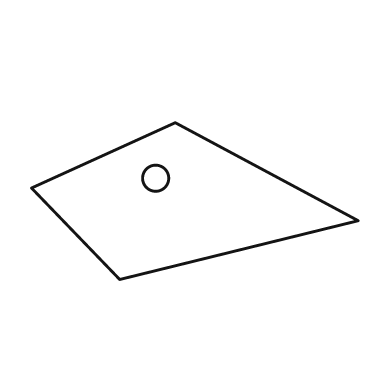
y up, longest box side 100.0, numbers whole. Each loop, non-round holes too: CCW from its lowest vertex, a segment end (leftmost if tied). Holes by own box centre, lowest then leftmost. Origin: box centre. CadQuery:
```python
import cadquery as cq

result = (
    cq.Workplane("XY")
    .moveTo(-23.0, -24.0)
    .lineTo(50.0, -6.0)
    .lineTo(-6.0, 24.0)
    .lineTo(-50.0, 4.0)
    .close()
    .moveTo(-12.0, 7.0)
    .circle(4.0)
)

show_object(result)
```